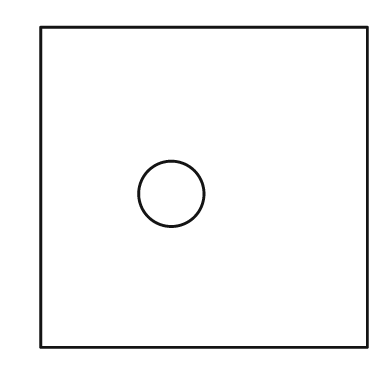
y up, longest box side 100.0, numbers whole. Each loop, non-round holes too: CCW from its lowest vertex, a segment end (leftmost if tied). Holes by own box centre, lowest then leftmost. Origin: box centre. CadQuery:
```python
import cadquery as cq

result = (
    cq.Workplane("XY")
    .moveTo(-50.0, -49.0)
    .lineTo(50.0, -49.0)
    .lineTo(50.0, 49.0)
    .lineTo(-50.0, 49.0)
    .close()
    .moveTo(-10.0, -2.0)
    .circle(10.0)
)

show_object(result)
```